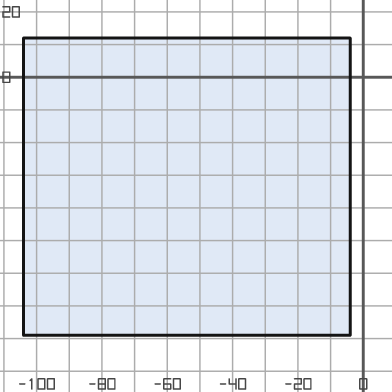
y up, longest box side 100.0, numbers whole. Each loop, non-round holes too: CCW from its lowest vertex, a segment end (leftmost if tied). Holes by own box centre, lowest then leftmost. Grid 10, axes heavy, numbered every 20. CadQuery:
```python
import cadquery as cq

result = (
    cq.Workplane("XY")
    .moveTo(-104.0, -79.0)
    .lineTo(-4.0, -79.0)
    .lineTo(-4.0, 12.0)
    .lineTo(-104.0, 12.0)
    .close()
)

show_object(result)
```